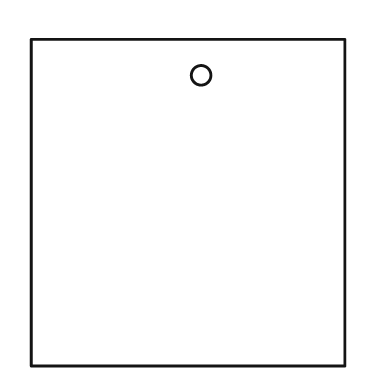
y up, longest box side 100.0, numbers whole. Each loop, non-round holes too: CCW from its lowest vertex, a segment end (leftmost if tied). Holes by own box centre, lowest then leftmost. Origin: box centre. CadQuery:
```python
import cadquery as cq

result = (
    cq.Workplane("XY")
    .moveTo(-48.0, -50.0)
    .lineTo(48.0, -50.0)
    .lineTo(48.0, 50.0)
    .lineTo(-48.0, 50.0)
    .close()
    .moveTo(4.0, 39.0)
    .circle(3.0)
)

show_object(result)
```